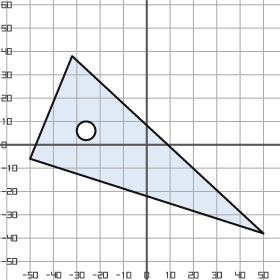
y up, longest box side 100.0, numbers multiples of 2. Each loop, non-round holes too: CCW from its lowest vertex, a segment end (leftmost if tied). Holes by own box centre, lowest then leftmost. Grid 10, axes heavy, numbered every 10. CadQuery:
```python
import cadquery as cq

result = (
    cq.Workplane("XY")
    .moveTo(50.0, -38.0)
    .lineTo(-32.0, 38.0)
    .lineTo(-50.0, -6.0)
    .close()
    .moveTo(-26.0, 6.0)
    .circle(4.0)
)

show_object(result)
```